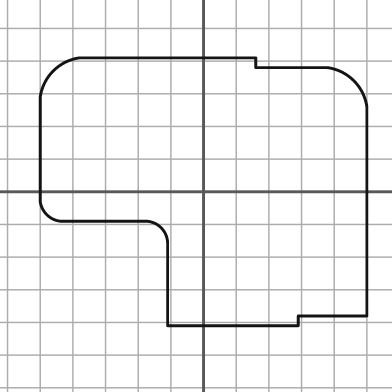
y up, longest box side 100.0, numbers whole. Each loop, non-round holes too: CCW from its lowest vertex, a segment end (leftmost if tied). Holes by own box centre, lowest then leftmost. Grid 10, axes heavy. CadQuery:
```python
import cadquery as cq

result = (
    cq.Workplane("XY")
    .moveTo(-11.0, -41.0)
    .lineTo(29.0, -41.0)
    .lineTo(29.0, -38.0)
    .lineTo(50.0, -38.0)
    .lineTo(50.0, 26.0)
    .threePointArc((46.0, 34.0), (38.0, 38.0))
    .lineTo(16.0, 38.0)
    .lineTo(16.0, 41.0)
    .lineTo(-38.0, 41.0)
    .threePointArc((-46.0, 37.0), (-50.0, 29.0))
    .lineTo(-50.0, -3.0)
    .threePointArc((-48.0, -7.0), (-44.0, -9.0))
    .lineTo(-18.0, -9.0)
    .threePointArc((-13.0, -11.0), (-11.0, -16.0))
    .close()
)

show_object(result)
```